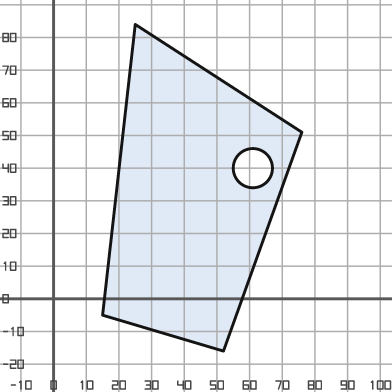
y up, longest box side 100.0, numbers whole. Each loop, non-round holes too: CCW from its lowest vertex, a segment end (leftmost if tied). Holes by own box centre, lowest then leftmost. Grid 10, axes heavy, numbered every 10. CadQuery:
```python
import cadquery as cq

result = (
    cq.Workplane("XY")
    .moveTo(52.0, -16.0)
    .lineTo(76.0, 51.0)
    .lineTo(25.0, 84.0)
    .lineTo(15.0, -5.0)
    .close()
    .moveTo(61.0, 40.0)
    .circle(6.0)
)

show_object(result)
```